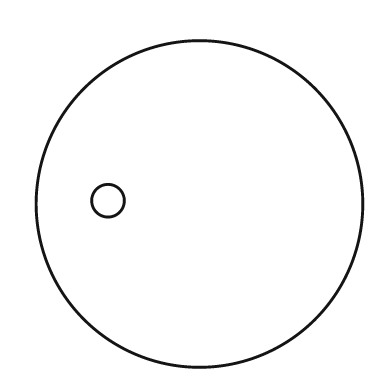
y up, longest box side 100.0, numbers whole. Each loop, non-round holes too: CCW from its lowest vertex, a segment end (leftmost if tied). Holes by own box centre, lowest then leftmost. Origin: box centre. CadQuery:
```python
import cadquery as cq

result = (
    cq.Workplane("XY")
    .moveTo(0.0, 0.0)
    .circle(50.0)
    .moveTo(-28.0, 1.0)
    .circle(5.0)
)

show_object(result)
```